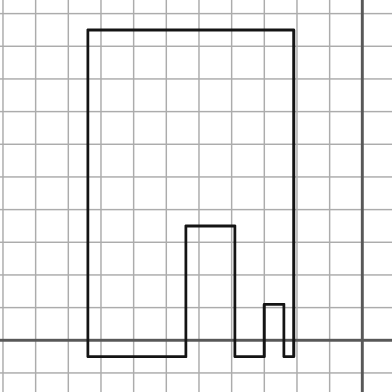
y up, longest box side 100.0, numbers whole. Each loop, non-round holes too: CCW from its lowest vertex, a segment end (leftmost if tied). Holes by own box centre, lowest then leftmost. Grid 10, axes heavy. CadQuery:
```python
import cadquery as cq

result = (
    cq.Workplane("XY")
    .moveTo(-84.0, -5.0)
    .lineTo(-54.0, -5.0)
    .lineTo(-54.0, 35.0)
    .lineTo(-39.0, 35.0)
    .lineTo(-39.0, -5.0)
    .lineTo(-30.0, -5.0)
    .lineTo(-30.0, 11.0)
    .lineTo(-24.0, 11.0)
    .lineTo(-24.0, -5.0)
    .lineTo(-21.0, -5.0)
    .lineTo(-21.0, 95.0)
    .lineTo(-84.0, 95.0)
    .close()
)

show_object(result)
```